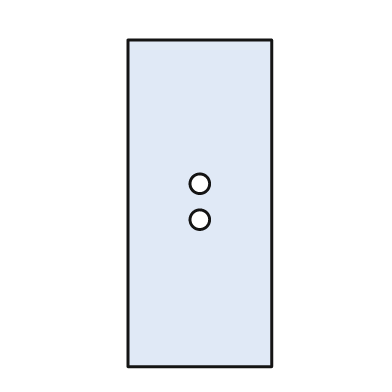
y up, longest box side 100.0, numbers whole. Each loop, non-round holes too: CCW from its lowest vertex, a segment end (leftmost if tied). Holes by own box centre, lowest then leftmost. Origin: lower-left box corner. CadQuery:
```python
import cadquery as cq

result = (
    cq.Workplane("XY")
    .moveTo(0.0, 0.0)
    .lineTo(44.0, 0.0)
    .lineTo(44.0, 100.0)
    .lineTo(0.0, 100.0)
    .close()
    .moveTo(22.0, 45.0)
    .circle(3.0)
    .moveTo(22.0, 56.0)
    .circle(3.0)
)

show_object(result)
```